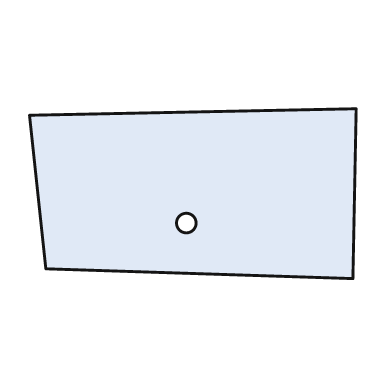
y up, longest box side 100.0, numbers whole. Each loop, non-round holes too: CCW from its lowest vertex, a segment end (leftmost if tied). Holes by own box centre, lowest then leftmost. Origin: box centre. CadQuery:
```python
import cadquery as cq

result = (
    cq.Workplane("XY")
    .moveTo(49.0, -26.0)
    .lineTo(50.0, 26.0)
    .lineTo(-50.0, 24.0)
    .lineTo(-45.0, -23.0)
    .close()
    .moveTo(-2.0, -9.0)
    .circle(3.0)
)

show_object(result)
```